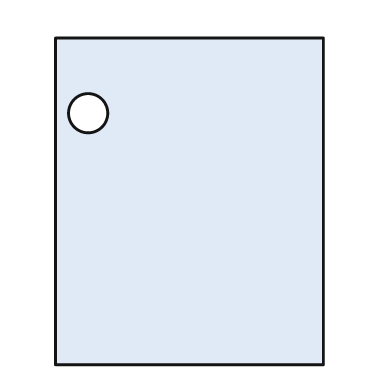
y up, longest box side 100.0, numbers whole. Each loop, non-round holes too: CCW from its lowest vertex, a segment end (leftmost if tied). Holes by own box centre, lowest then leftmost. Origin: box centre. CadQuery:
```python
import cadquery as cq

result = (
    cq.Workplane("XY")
    .moveTo(-41.0, -50.0)
    .lineTo(41.0, -50.0)
    .lineTo(41.0, 50.0)
    .lineTo(-41.0, 50.0)
    .close()
    .moveTo(-31.0, 27.0)
    .circle(6.0)
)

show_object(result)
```